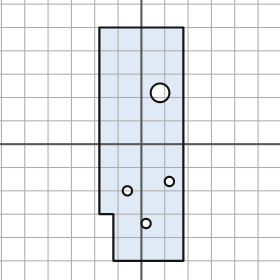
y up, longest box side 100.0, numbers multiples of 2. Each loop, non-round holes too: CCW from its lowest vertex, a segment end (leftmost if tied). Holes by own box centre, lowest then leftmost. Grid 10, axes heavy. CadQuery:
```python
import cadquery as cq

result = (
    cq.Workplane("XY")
    .moveTo(-12.0, -50.0)
    .lineTo(18.0, -50.0)
    .lineTo(18.0, 50.0)
    .lineTo(-18.0, 50.0)
    .lineTo(-18.0, -30.0)
    .lineTo(-12.0, -30.0)
    .close()
    .moveTo(2.0, -34.0)
    .circle(2.0)
    .moveTo(-6.0, -20.0)
    .circle(2.0)
    .moveTo(12.0, -16.0)
    .circle(2.0)
    .moveTo(8.0, 22.0)
    .circle(4.0)
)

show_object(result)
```